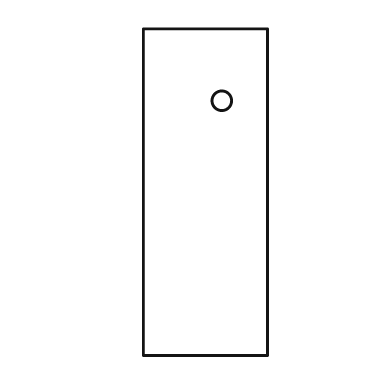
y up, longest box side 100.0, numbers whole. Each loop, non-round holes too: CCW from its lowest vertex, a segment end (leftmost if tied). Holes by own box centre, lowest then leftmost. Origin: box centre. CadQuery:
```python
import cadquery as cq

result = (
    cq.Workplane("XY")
    .moveTo(-19.0, -50.0)
    .lineTo(19.0, -50.0)
    .lineTo(19.0, 50.0)
    .lineTo(-19.0, 50.0)
    .close()
    .moveTo(5.0, 28.0)
    .circle(3.0)
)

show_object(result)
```